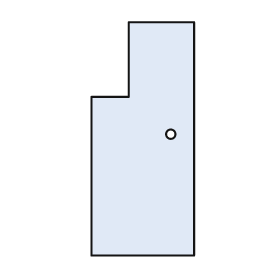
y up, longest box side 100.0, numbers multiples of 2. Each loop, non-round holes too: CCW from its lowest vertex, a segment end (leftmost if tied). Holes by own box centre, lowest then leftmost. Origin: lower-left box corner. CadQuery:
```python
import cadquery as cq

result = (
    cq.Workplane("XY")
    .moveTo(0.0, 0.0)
    .lineTo(44.0, 0.0)
    .lineTo(44.0, 100.0)
    .lineTo(16.0, 100.0)
    .lineTo(16.0, 68.0)
    .lineTo(0.0, 68.0)
    .close()
    .moveTo(34.0, 52.0)
    .circle(2.0)
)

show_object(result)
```